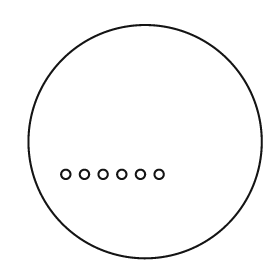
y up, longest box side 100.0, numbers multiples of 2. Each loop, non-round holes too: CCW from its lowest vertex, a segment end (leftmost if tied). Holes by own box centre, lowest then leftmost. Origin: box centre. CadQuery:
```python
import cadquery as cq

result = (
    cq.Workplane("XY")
    .moveTo(0.0, 0.0)
    .circle(50.0)
    .moveTo(-34.0, -14.0)
    .circle(2.0)
    .moveTo(-26.0, -14.0)
    .circle(2.0)
    .moveTo(-18.0, -14.0)
    .circle(2.0)
    .moveTo(-10.0, -14.0)
    .circle(2.0)
    .moveTo(-2.0, -14.0)
    .circle(2.0)
    .moveTo(6.0, -14.0)
    .circle(2.0)
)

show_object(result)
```